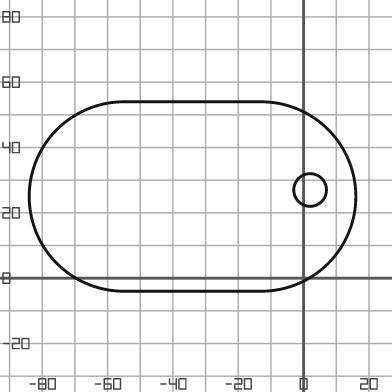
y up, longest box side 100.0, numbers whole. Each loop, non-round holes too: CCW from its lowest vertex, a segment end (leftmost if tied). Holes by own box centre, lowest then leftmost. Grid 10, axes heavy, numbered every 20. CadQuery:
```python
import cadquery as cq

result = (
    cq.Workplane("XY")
    .moveTo(-55.0, -4.0)
    .lineTo(-13.0, -4.0)
    .threePointArc((16.0, 25.0), (-13.0, 54.0))
    .lineTo(-55.0, 54.0)
    .threePointArc((-84.0, 25.0), (-55.0, -4.0))
    .close()
    .moveTo(2.0, 27.0)
    .circle(5.0)
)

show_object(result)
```